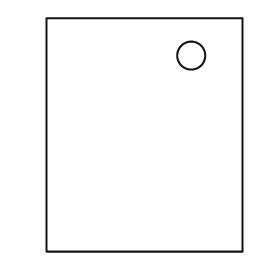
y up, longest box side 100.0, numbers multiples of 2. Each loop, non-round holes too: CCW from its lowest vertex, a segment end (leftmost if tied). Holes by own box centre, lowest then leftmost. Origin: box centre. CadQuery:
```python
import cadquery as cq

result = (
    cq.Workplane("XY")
    .moveTo(-42.0, -50.0)
    .lineTo(42.0, -50.0)
    .lineTo(42.0, 50.0)
    .lineTo(-42.0, 50.0)
    .close()
    .moveTo(20.0, 34.0)
    .circle(6.0)
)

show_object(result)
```